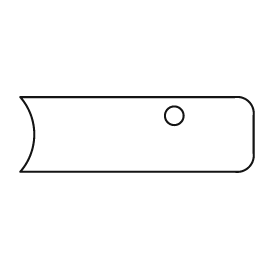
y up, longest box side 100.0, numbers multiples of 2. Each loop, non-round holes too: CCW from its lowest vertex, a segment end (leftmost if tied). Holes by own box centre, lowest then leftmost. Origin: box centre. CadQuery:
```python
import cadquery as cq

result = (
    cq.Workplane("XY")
    .moveTo(-50.0, -16.0)
    .lineTo(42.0, -16.0)
    .threePointArc((48.0, -14.0), (50.0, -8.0))
    .lineTo(50.0, 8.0)
    .threePointArc((48.0, 14.0), (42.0, 16.0))
    .lineTo(-50.0, 16.0)
    .threePointArc((-44.0, 0.0), (-50.0, -16.0))
    .close()
    .moveTo(16.0, 8.0)
    .circle(4.0)
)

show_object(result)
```